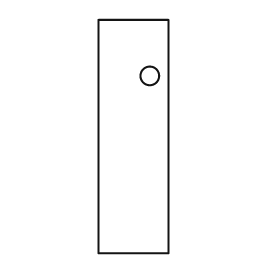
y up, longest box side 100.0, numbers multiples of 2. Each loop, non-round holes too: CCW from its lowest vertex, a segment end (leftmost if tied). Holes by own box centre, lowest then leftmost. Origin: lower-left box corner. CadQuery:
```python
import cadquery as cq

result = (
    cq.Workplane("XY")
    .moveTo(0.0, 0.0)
    .lineTo(30.0, 0.0)
    .lineTo(30.0, 100.0)
    .lineTo(0.0, 100.0)
    .close()
    .moveTo(22.0, 76.0)
    .circle(4.0)
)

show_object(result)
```